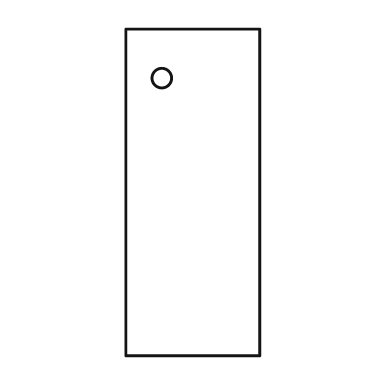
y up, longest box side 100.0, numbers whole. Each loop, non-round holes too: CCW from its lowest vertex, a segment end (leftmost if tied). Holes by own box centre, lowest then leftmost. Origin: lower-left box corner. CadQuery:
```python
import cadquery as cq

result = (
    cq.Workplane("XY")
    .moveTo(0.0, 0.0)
    .lineTo(41.0, 0.0)
    .lineTo(41.0, 100.0)
    .lineTo(0.0, 100.0)
    .close()
    .moveTo(11.0, 85.0)
    .circle(3.0)
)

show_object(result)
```